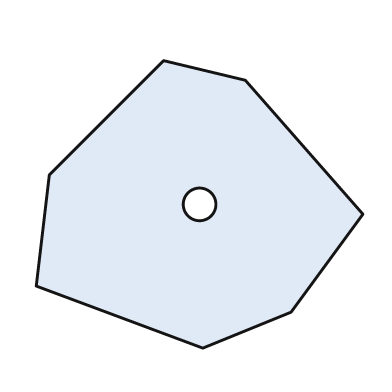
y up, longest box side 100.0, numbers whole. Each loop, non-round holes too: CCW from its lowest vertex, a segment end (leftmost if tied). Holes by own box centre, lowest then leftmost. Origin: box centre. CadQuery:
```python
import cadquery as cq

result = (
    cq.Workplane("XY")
    .moveTo(1.0, -44.0)
    .lineTo(28.0, -33.0)
    .lineTo(50.0, -3.0)
    .lineTo(14.0, 38.0)
    .lineTo(-11.0, 44.0)
    .lineTo(-46.0, 9.0)
    .lineTo(-50.0, -25.0)
    .close()
    .moveTo(0.0, 0.0)
    .circle(5.0)
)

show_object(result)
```